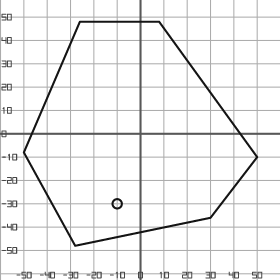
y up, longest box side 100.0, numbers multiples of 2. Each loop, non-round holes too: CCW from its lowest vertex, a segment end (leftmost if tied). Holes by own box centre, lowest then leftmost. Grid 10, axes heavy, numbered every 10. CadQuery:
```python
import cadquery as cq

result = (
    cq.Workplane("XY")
    .moveTo(-28.0, -48.0)
    .lineTo(30.0, -36.0)
    .lineTo(50.0, -10.0)
    .lineTo(8.0, 48.0)
    .lineTo(-26.0, 48.0)
    .lineTo(-50.0, -8.0)
    .close()
    .moveTo(-10.0, -30.0)
    .circle(2.0)
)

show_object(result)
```